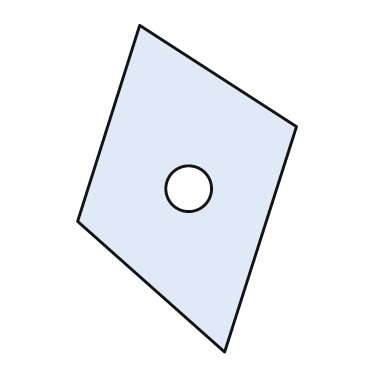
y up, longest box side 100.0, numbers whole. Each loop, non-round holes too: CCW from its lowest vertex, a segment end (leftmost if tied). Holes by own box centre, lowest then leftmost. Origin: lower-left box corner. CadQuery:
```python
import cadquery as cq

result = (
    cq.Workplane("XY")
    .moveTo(45.0, 0.0)
    .lineTo(67.0, 69.0)
    .lineTo(19.0, 100.0)
    .lineTo(0.0, 40.0)
    .close()
    .moveTo(34.0, 50.0)
    .circle(7.0)
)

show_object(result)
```